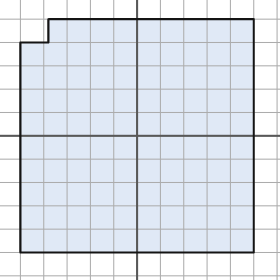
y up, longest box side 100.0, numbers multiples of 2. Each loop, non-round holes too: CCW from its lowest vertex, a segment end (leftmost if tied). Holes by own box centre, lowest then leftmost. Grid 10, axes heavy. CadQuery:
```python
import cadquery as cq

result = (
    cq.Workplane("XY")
    .moveTo(-50.0, -50.0)
    .lineTo(50.0, -50.0)
    .lineTo(50.0, 50.0)
    .lineTo(-38.0, 50.0)
    .lineTo(-38.0, 40.0)
    .lineTo(-50.0, 40.0)
    .close()
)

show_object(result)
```